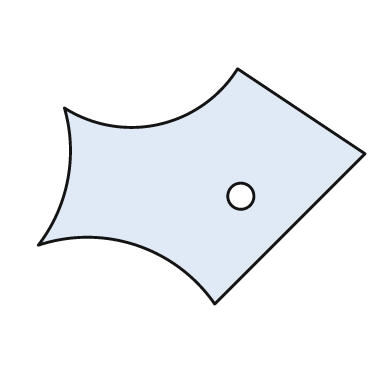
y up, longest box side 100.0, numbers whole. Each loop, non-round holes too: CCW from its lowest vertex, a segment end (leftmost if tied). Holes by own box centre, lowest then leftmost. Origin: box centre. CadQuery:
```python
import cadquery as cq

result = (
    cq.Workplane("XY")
    .moveTo(4.0, -36.0)
    .lineTo(50.0, 10.0)
    .lineTo(11.0, 36.0)
    .threePointArc((-13.0, 19.0), (-42.0, 24.0))
    .threePointArc((-41.0, 2.0), (-50.0, -18.0))
    .threePointArc((-20.0, -18.0), (4.0, -36.0))
    .close()
    .moveTo(12.0, -3.0)
    .circle(4.0)
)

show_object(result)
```